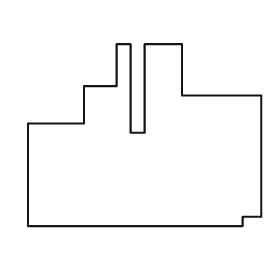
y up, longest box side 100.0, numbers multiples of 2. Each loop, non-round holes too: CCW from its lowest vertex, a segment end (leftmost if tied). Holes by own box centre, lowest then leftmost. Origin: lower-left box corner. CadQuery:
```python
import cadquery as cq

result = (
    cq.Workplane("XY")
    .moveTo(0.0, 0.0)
    .lineTo(92.0, 0.0)
    .lineTo(92.0, 4.0)
    .lineTo(100.0, 4.0)
    .lineTo(100.0, 56.0)
    .lineTo(66.0, 56.0)
    .lineTo(66.0, 78.0)
    .lineTo(50.0, 78.0)
    .lineTo(50.0, 40.0)
    .lineTo(44.0, 40.0)
    .lineTo(44.0, 78.0)
    .lineTo(38.0, 78.0)
    .lineTo(38.0, 60.0)
    .lineTo(24.0, 60.0)
    .lineTo(24.0, 44.0)
    .lineTo(0.0, 44.0)
    .close()
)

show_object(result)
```